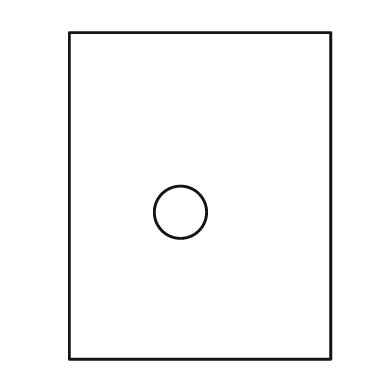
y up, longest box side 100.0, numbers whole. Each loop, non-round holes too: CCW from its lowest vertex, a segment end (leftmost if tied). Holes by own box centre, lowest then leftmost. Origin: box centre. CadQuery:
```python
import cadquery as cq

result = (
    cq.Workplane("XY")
    .moveTo(-40.0, -50.0)
    .lineTo(40.0, -50.0)
    .lineTo(40.0, 50.0)
    .lineTo(-40.0, 50.0)
    .close()
    .moveTo(-6.0, -5.0)
    .circle(8.0)
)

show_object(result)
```